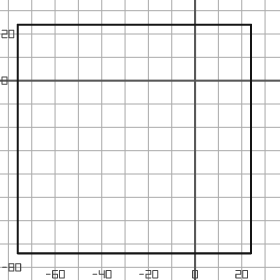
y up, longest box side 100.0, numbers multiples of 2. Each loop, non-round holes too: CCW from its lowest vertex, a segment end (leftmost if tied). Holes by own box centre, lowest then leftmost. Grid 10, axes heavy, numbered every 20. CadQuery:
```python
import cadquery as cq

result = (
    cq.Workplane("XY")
    .moveTo(-76.0, -74.0)
    .lineTo(24.0, -74.0)
    .lineTo(24.0, 24.0)
    .lineTo(-76.0, 24.0)
    .close()
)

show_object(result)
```